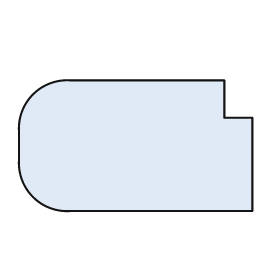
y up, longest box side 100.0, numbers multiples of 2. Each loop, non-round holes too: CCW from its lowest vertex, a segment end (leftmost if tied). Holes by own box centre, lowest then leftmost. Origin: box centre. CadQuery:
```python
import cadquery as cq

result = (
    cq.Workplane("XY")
    .moveTo(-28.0, -28.0)
    .lineTo(50.0, -28.0)
    .lineTo(50.0, 12.0)
    .lineTo(38.0, 12.0)
    .lineTo(38.0, 28.0)
    .lineTo(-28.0, 28.0)
    .threePointArc((-44.0, 22.0), (-50.0, 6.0))
    .lineTo(-50.0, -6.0)
    .threePointArc((-44.0, -22.0), (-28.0, -28.0))
    .close()
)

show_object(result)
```